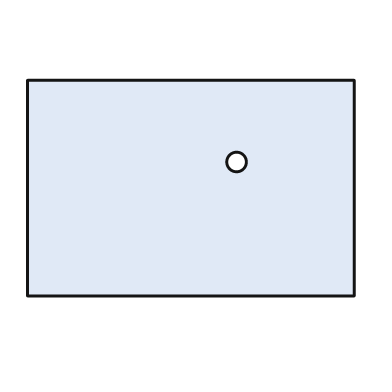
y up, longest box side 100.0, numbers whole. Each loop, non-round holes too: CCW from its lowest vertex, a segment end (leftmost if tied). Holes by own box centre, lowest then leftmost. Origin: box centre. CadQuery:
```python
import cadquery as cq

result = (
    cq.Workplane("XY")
    .moveTo(-50.0, -33.0)
    .lineTo(50.0, -33.0)
    .lineTo(50.0, 33.0)
    .lineTo(-50.0, 33.0)
    .close()
    .moveTo(14.0, 8.0)
    .circle(3.0)
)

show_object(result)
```